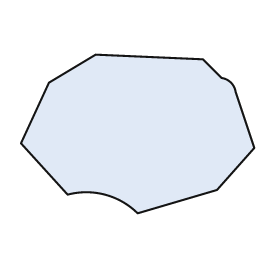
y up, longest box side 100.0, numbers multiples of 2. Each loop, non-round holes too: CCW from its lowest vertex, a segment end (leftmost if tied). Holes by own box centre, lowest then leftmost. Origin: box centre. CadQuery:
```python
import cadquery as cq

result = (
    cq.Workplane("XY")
    .moveTo(0.0, -34.0)
    .lineTo(34.0, -24.0)
    .lineTo(50.0, -6.0)
    .lineTo(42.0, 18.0)
    .threePointArc((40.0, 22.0), (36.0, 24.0))
    .lineTo(28.0, 32.0)
    .lineTo(-18.0, 34.0)
    .lineTo(-38.0, 22.0)
    .lineTo(-50.0, -4.0)
    .lineTo(-30.0, -26.0)
    .threePointArc((-14.0, -26.0), (0.0, -34.0))
    .close()
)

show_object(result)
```